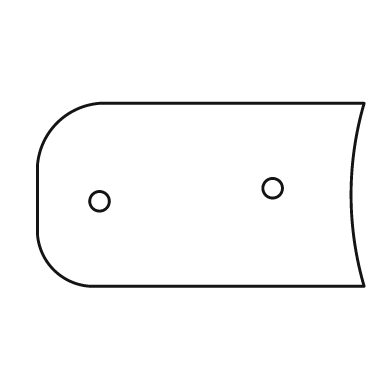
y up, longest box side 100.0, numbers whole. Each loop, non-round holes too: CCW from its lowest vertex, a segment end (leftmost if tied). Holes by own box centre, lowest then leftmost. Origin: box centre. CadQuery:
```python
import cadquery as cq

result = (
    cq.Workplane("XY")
    .moveTo(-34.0, -28.0)
    .lineTo(50.0, -28.0)
    .threePointArc((46.0, 0.0), (50.0, 28.0))
    .lineTo(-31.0, 28.0)
    .threePointArc((-44.0, 22.0), (-50.0, 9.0))
    .lineTo(-50.0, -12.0)
    .threePointArc((-45.0, -23.0), (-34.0, -28.0))
    .close()
    .moveTo(-31.0, -2.0)
    .circle(3.0)
    .moveTo(22.0, 2.0)
    .circle(3.0)
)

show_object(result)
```